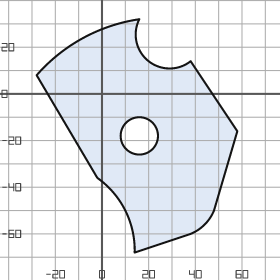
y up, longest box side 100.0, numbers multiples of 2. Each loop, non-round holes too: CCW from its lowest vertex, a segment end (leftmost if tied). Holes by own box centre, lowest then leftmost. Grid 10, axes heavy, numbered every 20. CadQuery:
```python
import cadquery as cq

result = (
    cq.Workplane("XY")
    .moveTo(14.0, -68.0)
    .lineTo(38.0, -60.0)
    .threePointArc((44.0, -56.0), (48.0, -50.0))
    .lineTo(58.0, -16.0)
    .lineTo(38.0, 14.0)
    .threePointArc((20.0, 14.0), (16.0, 32.0))
    .threePointArc((-8.0, 24.0), (-28.0, 8.0))
    .lineTo(-2.0, -36.0)
    .threePointArc((10.0, -50.0), (14.0, -68.0))
    .close()
    .moveTo(16.0, -18.0)
    .circle(8.0)
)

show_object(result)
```